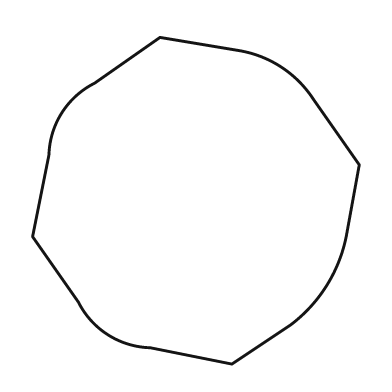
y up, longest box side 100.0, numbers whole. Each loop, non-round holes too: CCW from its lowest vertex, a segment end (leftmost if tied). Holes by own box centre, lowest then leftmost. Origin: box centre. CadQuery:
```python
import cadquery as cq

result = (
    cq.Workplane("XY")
    .moveTo(11.0, -50.0)
    .lineTo(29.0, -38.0)
    .threePointArc((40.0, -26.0), (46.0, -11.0))
    .lineTo(50.0, 11.0)
    .lineTo(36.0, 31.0)
    .threePointArc((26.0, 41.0), (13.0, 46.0))
    .lineTo(-11.0, 50.0)
    .lineTo(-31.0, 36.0)
    .threePointArc((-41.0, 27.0), (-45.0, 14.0))
    .lineTo(-50.0, -11.0)
    .lineTo(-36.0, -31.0)
    .threePointArc((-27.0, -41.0), (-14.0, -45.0))
    .close()
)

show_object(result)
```